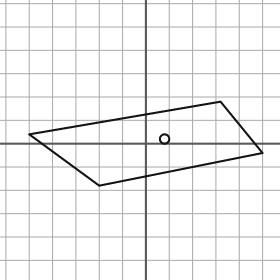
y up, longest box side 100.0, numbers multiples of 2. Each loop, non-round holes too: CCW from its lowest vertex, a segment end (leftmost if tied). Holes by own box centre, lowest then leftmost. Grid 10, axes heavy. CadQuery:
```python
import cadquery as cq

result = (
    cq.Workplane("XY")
    .moveTo(-20.0, -18.0)
    .lineTo(50.0, -4.0)
    .lineTo(32.0, 18.0)
    .lineTo(-50.0, 4.0)
    .close()
    .moveTo(8.0, 2.0)
    .circle(2.0)
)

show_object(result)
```